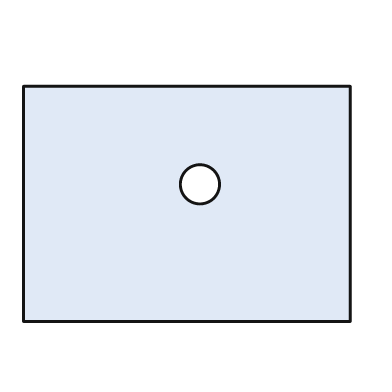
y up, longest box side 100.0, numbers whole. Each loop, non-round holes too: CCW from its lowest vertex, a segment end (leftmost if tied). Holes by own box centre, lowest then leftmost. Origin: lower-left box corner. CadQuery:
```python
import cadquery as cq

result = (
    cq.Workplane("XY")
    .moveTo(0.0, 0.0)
    .lineTo(100.0, 0.0)
    .lineTo(100.0, 72.0)
    .lineTo(0.0, 72.0)
    .close()
    .moveTo(54.0, 42.0)
    .circle(6.0)
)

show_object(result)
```